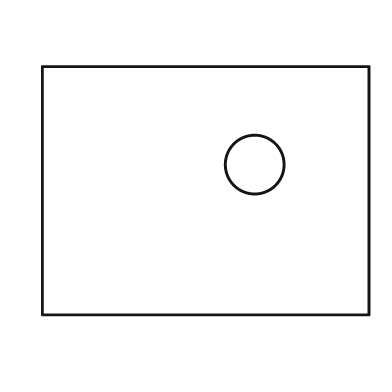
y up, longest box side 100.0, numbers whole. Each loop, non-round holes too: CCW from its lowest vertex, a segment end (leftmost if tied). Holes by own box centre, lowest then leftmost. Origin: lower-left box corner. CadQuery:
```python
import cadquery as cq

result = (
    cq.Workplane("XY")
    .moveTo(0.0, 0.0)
    .lineTo(100.0, 0.0)
    .lineTo(100.0, 76.0)
    .lineTo(0.0, 76.0)
    .close()
    .moveTo(65.0, 46.0)
    .circle(9.0)
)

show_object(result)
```